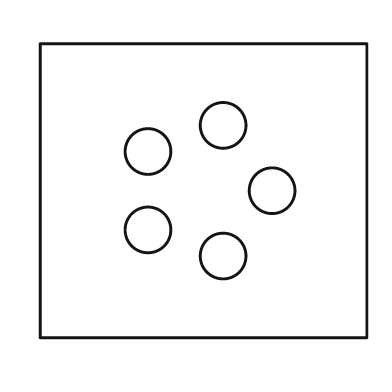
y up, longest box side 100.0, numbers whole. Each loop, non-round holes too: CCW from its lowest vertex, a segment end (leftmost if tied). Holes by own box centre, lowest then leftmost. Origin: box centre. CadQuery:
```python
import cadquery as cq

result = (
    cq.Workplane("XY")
    .moveTo(-50.0, -45.0)
    .lineTo(50.0, -45.0)
    .lineTo(50.0, 45.0)
    .lineTo(-50.0, 45.0)
    .close()
    .moveTo(6.0, -20.0)
    .circle(7.0)
    .moveTo(-17.0, -12.0)
    .circle(7.0)
    .moveTo(21.0, 0.0)
    .circle(7.0)
    .moveTo(-17.0, 12.0)
    .circle(7.0)
    .moveTo(6.0, 20.0)
    .circle(7.0)
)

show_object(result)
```